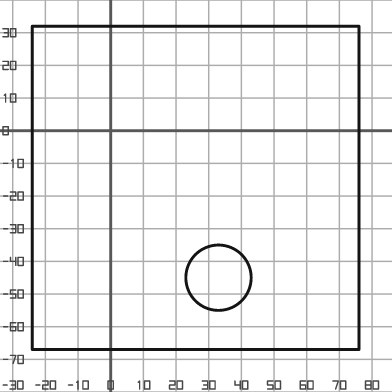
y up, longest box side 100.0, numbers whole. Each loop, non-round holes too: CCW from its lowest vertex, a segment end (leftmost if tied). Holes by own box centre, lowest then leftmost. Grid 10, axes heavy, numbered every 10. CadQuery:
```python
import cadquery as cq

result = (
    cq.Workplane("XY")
    .moveTo(-24.0, -67.0)
    .lineTo(76.0, -67.0)
    .lineTo(76.0, 32.0)
    .lineTo(-24.0, 32.0)
    .close()
    .moveTo(33.0, -45.0)
    .circle(10.0)
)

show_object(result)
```